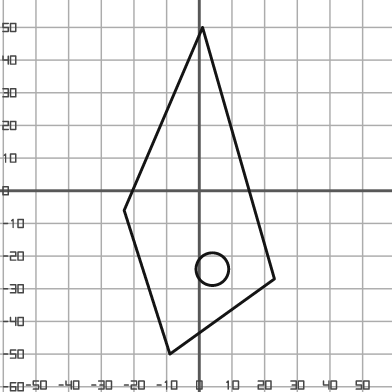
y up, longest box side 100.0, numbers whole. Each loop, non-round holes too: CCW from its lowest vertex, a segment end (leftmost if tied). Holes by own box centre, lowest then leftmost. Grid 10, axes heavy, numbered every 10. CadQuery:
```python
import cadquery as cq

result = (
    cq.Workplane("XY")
    .moveTo(-9.0, -50.0)
    .lineTo(23.0, -27.0)
    .lineTo(1.0, 50.0)
    .lineTo(-23.0, -6.0)
    .close()
    .moveTo(4.0, -24.0)
    .circle(5.0)
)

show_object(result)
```